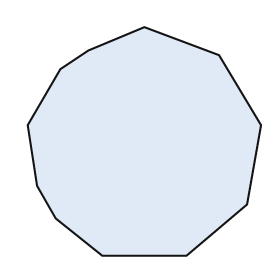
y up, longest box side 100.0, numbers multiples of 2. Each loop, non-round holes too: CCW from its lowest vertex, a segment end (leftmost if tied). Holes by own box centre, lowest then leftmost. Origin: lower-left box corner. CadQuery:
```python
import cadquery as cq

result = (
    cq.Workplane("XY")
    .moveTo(32.0, 0.0)
    .lineTo(68.0, 0.0)
    .lineTo(94.0, 22.0)
    .lineTo(100.0, 56.0)
    .lineTo(82.0, 86.0)
    .lineTo(50.0, 98.0)
    .lineTo(26.0, 88.0)
    .lineTo(14.0, 80.0)
    .lineTo(0.0, 56.0)
    .lineTo(4.0, 30.0)
    .lineTo(12.0, 16.0)
    .close()
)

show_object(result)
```